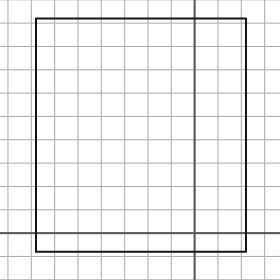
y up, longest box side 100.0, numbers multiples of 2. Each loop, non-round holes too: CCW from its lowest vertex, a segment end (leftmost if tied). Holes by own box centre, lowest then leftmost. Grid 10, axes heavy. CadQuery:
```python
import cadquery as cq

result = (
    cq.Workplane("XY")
    .moveTo(-68.0, -8.0)
    .lineTo(22.0, -8.0)
    .lineTo(22.0, 92.0)
    .lineTo(-68.0, 92.0)
    .close()
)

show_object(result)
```